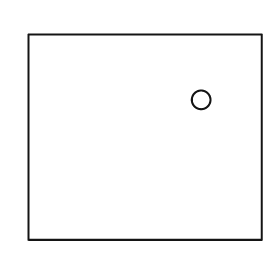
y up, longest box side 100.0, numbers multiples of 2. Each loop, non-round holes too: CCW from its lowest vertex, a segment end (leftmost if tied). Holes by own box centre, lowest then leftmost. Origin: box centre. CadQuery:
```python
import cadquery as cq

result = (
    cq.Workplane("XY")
    .moveTo(-50.0, -44.0)
    .lineTo(50.0, -44.0)
    .lineTo(50.0, 44.0)
    .lineTo(-50.0, 44.0)
    .close()
    .moveTo(24.0, 16.0)
    .circle(4.0)
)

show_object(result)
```